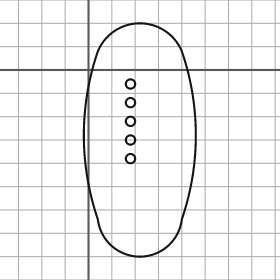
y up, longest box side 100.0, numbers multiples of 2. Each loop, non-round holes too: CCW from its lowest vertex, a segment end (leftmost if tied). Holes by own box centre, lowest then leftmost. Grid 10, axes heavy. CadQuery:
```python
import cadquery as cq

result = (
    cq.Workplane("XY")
    .moveTo(4.0, -64.0)
    .threePointArc((22.0, -80.0), (40.0, -64.0))
    .threePointArc((46.0, -28.0), (40.0, 8.0))
    .threePointArc((22.0, 20.0), (4.0, 8.0))
    .threePointArc((-2.0, -28.0), (4.0, -64.0))
    .close()
    .moveTo(18.0, -38.0)
    .circle(2.0)
    .moveTo(18.0, -30.0)
    .circle(2.0)
    .moveTo(18.0, -22.0)
    .circle(2.0)
    .moveTo(18.0, -14.0)
    .circle(2.0)
    .moveTo(18.0, -6.0)
    .circle(2.0)
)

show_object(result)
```